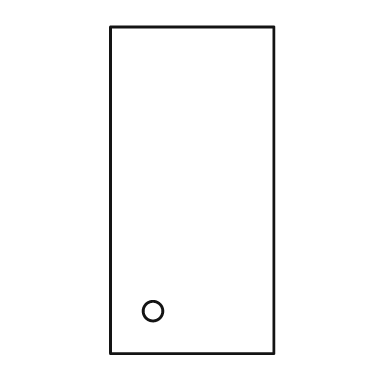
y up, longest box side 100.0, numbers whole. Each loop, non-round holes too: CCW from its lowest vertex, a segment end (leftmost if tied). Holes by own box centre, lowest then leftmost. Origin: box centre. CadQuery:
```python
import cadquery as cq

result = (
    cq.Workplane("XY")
    .moveTo(-25.0, -50.0)
    .lineTo(25.0, -50.0)
    .lineTo(25.0, 50.0)
    .lineTo(-25.0, 50.0)
    .close()
    .moveTo(-12.0, -37.0)
    .circle(3.0)
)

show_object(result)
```